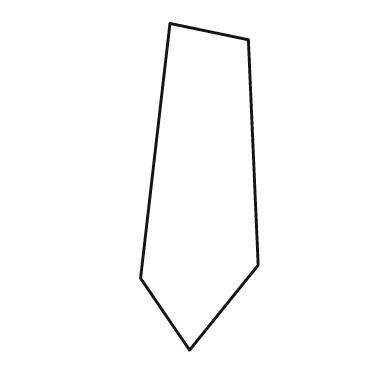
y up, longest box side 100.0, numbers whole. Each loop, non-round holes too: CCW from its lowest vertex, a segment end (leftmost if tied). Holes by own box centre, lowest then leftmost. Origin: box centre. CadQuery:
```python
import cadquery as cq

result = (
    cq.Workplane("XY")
    .moveTo(-3.0, -50.0)
    .lineTo(18.0, -24.0)
    .lineTo(15.0, 45.0)
    .lineTo(-9.0, 50.0)
    .lineTo(-18.0, -28.0)
    .close()
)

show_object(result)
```